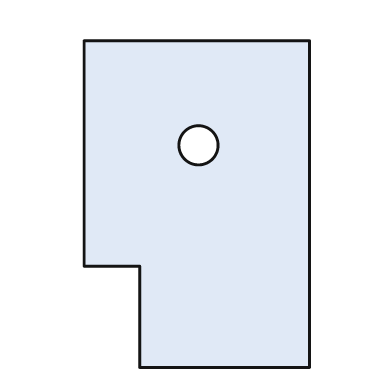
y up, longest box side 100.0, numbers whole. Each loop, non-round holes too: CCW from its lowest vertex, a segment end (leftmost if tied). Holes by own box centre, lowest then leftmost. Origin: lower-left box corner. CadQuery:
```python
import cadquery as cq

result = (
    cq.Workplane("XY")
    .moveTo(17.0, 0.0)
    .lineTo(69.0, 0.0)
    .lineTo(69.0, 100.0)
    .lineTo(0.0, 100.0)
    .lineTo(0.0, 31.0)
    .lineTo(17.0, 31.0)
    .close()
    .moveTo(35.0, 68.0)
    .circle(6.0)
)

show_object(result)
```